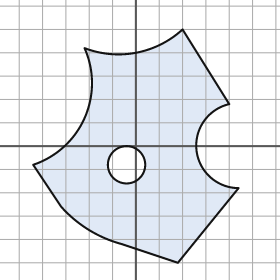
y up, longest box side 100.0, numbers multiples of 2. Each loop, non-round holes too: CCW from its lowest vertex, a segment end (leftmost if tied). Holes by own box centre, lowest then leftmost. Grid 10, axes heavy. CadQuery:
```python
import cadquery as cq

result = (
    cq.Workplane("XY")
    .moveTo(18.0, -50.0)
    .lineTo(44.0, -18.0)
    .threePointArc((26.0, -2.0), (40.0, 18.0))
    .lineTo(20.0, 50.0)
    .threePointArc((0.0, 40.0), (-22.0, 42.0))
    .threePointArc((-22.0, 12.0), (-44.0, -8.0))
    .lineTo(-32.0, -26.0)
    .threePointArc((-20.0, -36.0), (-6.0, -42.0))
    .close()
    .moveTo(-4.0, -8.0)
    .circle(8.0)
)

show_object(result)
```